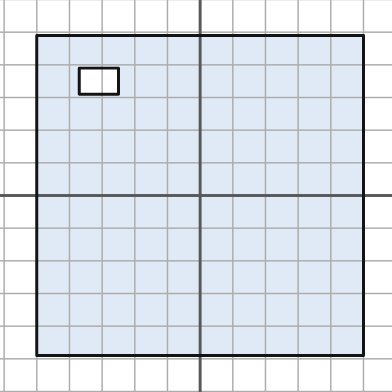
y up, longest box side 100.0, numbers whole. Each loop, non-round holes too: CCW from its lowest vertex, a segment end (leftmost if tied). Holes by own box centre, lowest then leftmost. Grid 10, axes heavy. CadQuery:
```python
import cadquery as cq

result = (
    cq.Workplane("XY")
    .moveTo(-50.0, -49.0)
    .lineTo(50.0, -49.0)
    .lineTo(50.0, 49.0)
    .lineTo(-50.0, 49.0)
    .close()
    .moveTo(-37.0, 31.0)
    .lineTo(-25.0, 31.0)
    .lineTo(-25.0, 39.0)
    .lineTo(-37.0, 39.0)
    .close()
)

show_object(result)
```